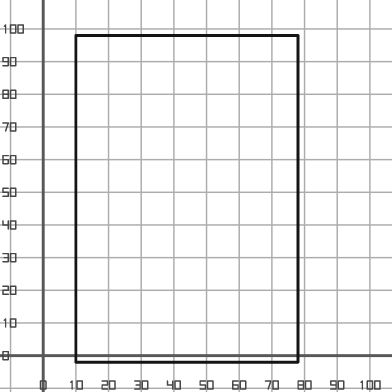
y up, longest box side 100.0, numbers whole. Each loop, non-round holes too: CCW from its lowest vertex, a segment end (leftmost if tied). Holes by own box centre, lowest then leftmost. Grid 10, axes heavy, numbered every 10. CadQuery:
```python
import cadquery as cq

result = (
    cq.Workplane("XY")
    .moveTo(10.0, -2.0)
    .lineTo(78.0, -2.0)
    .lineTo(78.0, 98.0)
    .lineTo(10.0, 98.0)
    .close()
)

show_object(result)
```